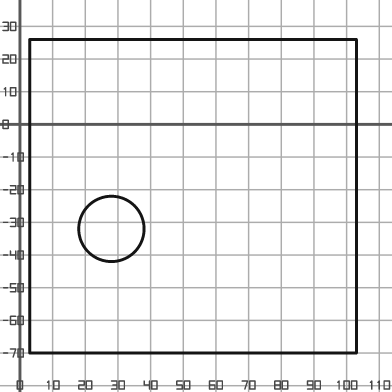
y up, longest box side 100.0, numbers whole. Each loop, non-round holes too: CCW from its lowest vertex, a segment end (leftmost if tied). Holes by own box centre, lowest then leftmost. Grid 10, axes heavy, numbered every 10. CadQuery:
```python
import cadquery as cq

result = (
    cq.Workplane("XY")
    .moveTo(3.0, -70.0)
    .lineTo(103.0, -70.0)
    .lineTo(103.0, 26.0)
    .lineTo(3.0, 26.0)
    .close()
    .moveTo(28.0, -32.0)
    .circle(10.0)
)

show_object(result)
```